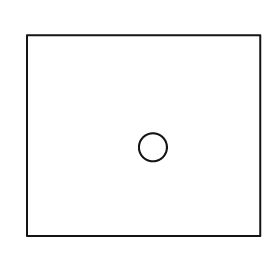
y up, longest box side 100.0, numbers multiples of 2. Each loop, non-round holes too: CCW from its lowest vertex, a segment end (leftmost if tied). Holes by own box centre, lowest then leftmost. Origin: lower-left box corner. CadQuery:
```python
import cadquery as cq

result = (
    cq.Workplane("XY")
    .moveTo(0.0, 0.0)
    .lineTo(100.0, 0.0)
    .lineTo(100.0, 86.0)
    .lineTo(0.0, 86.0)
    .close()
    .moveTo(54.0, 38.0)
    .circle(6.0)
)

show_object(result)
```